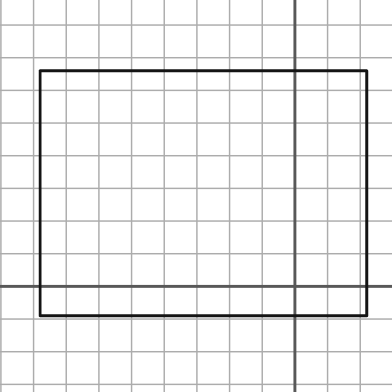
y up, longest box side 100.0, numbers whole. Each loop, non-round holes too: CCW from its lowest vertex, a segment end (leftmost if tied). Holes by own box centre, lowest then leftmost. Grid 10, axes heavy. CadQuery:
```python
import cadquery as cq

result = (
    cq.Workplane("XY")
    .moveTo(-78.0, -9.0)
    .lineTo(22.0, -9.0)
    .lineTo(22.0, 66.0)
    .lineTo(-78.0, 66.0)
    .close()
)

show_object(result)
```